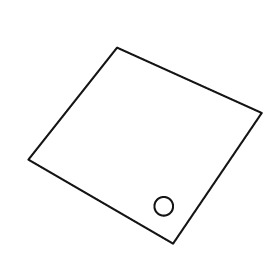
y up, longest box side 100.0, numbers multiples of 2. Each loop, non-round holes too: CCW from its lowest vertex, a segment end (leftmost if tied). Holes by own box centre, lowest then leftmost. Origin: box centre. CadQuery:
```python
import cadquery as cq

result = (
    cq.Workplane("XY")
    .moveTo(12.0, -42.0)
    .lineTo(50.0, 14.0)
    .lineTo(-12.0, 42.0)
    .lineTo(-50.0, -6.0)
    .close()
    .moveTo(8.0, -26.0)
    .circle(4.0)
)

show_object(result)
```